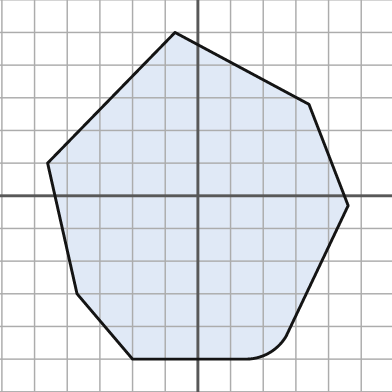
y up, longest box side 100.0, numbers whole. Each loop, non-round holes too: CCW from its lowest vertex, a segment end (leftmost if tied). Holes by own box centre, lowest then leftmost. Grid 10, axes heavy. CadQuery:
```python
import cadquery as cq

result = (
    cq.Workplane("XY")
    .moveTo(-20.0, -50.0)
    .lineTo(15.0, -50.0)
    .threePointArc((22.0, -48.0), (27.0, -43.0))
    .lineTo(46.0, -3.0)
    .lineTo(34.0, 28.0)
    .lineTo(-7.0, 50.0)
    .lineTo(-46.0, 10.0)
    .lineTo(-37.0, -30.0)
    .close()
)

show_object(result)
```